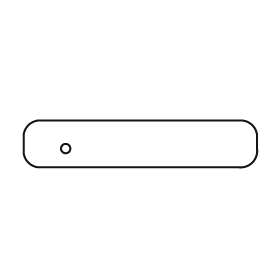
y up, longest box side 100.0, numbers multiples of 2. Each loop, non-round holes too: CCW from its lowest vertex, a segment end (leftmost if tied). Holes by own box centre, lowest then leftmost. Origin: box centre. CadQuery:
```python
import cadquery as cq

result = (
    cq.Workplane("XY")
    .moveTo(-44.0, -10.0)
    .lineTo(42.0, -10.0)
    .threePointArc((48.0, -8.0), (50.0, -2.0))
    .lineTo(50.0, 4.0)
    .threePointArc((48.0, 8.0), (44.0, 10.0))
    .lineTo(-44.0, 10.0)
    .threePointArc((-48.0, 8.0), (-50.0, 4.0))
    .lineTo(-50.0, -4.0)
    .threePointArc((-48.0, -8.0), (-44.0, -10.0))
    .close()
    .moveTo(-32.0, -2.0)
    .circle(2.0)
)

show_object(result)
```